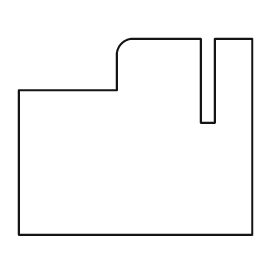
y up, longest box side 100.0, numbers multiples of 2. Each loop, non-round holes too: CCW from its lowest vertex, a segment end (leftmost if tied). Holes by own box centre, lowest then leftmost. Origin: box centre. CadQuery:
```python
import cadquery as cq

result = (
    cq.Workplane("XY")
    .moveTo(-50.0, -42.0)
    .lineTo(50.0, -42.0)
    .lineTo(50.0, 42.0)
    .lineTo(34.0, 42.0)
    .lineTo(34.0, 6.0)
    .lineTo(28.0, 6.0)
    .lineTo(28.0, 42.0)
    .lineTo(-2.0, 42.0)
    .threePointArc((-6.0, 40.0), (-8.0, 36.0))
    .lineTo(-8.0, 20.0)
    .lineTo(-50.0, 20.0)
    .close()
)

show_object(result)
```